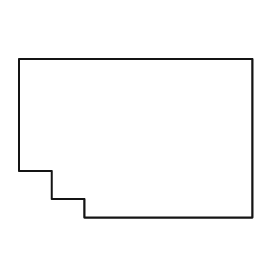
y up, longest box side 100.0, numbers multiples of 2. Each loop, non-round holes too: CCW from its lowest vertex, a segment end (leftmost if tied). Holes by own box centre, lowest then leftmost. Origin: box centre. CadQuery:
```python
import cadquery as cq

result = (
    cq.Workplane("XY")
    .moveTo(-22.0, -34.0)
    .lineTo(50.0, -34.0)
    .lineTo(50.0, 34.0)
    .lineTo(-50.0, 34.0)
    .lineTo(-50.0, -14.0)
    .lineTo(-36.0, -14.0)
    .lineTo(-36.0, -26.0)
    .lineTo(-22.0, -26.0)
    .close()
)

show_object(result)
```